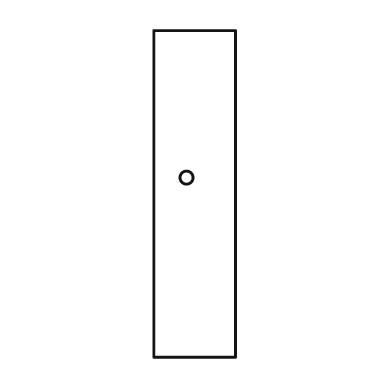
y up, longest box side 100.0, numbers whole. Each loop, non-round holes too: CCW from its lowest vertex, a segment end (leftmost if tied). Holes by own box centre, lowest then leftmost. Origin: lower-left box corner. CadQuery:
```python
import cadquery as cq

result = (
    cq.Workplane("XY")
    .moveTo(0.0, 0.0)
    .lineTo(25.0, 0.0)
    .lineTo(25.0, 100.0)
    .lineTo(0.0, 100.0)
    .close()
    .moveTo(10.0, 55.0)
    .circle(2.0)
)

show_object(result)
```